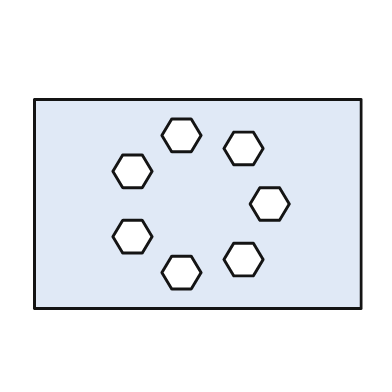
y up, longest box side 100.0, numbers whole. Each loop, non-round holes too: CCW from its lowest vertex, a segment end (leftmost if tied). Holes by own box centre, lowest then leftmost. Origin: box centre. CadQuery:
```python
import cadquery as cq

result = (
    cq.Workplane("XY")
    .moveTo(-50.0, -32.0)
    .lineTo(50.0, -32.0)
    .lineTo(50.0, 32.0)
    .lineTo(-50.0, 32.0)
    .close()
    .moveTo(-8.0, -26.0)
    .lineTo(-2.0, -26.0)
    .lineTo(1.0, -21.0)
    .lineTo(-2.0, -16.0)
    .lineTo(-8.0, -16.0)
    .lineTo(-11.0, -21.0)
    .close()
    .moveTo(11.0, -22.0)
    .lineTo(17.0, -22.0)
    .lineTo(20.0, -17.0)
    .lineTo(17.0, -12.0)
    .lineTo(11.0, -12.0)
    .lineTo(8.0, -17.0)
    .close()
    .moveTo(-23.0, -15.0)
    .lineTo(-17.0, -15.0)
    .lineTo(-14.0, -10.0)
    .lineTo(-17.0, -5.0)
    .lineTo(-23.0, -5.0)
    .lineTo(-26.0, -10.0)
    .close()
    .moveTo(19.0, -5.0)
    .lineTo(25.0, -5.0)
    .lineTo(28.0, 0.0)
    .lineTo(25.0, 5.0)
    .lineTo(19.0, 5.0)
    .lineTo(16.0, 0.0)
    .close()
    .moveTo(-23.0, 5.0)
    .lineTo(-17.0, 5.0)
    .lineTo(-14.0, 10.0)
    .lineTo(-17.0, 15.0)
    .lineTo(-23.0, 15.0)
    .lineTo(-26.0, 10.0)
    .close()
    .moveTo(11.0, 12.0)
    .lineTo(17.0, 12.0)
    .lineTo(20.0, 17.0)
    .lineTo(17.0, 22.0)
    .lineTo(11.0, 22.0)
    .lineTo(8.0, 17.0)
    .close()
    .moveTo(-8.0, 16.0)
    .lineTo(-2.0, 16.0)
    .lineTo(1.0, 21.0)
    .lineTo(-2.0, 26.0)
    .lineTo(-8.0, 26.0)
    .lineTo(-11.0, 21.0)
    .close()
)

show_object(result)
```